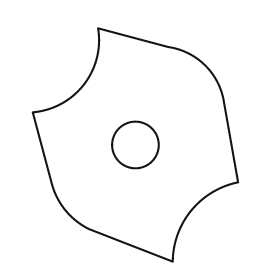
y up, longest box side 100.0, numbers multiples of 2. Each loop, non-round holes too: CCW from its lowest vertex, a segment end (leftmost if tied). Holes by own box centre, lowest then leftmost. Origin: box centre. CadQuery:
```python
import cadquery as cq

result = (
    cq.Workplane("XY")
    .moveTo(16.0, -50.0)
    .threePointArc((24.0, -28.0), (44.0, -16.0))
    .lineTo(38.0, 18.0)
    .threePointArc((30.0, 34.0), (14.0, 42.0))
    .lineTo(-16.0, 50.0)
    .threePointArc((-22.0, 26.0), (-44.0, 14.0))
    .lineTo(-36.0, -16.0)
    .threePointArc((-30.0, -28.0), (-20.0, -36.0))
    .close()
    .moveTo(0.0, 0.0)
    .circle(10.0)
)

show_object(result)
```